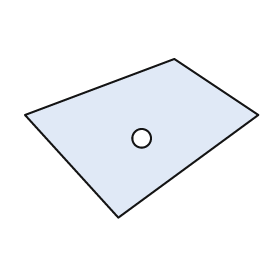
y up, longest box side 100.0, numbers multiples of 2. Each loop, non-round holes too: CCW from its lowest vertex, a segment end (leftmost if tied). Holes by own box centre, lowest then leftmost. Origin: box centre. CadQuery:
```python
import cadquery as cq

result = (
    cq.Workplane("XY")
    .moveTo(-10.0, -34.0)
    .lineTo(50.0, 10.0)
    .lineTo(14.0, 34.0)
    .lineTo(-50.0, 10.0)
    .close()
    .moveTo(0.0, 0.0)
    .circle(4.0)
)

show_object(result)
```